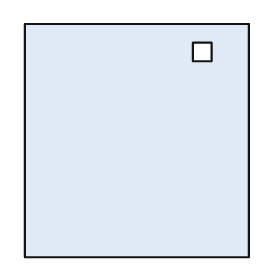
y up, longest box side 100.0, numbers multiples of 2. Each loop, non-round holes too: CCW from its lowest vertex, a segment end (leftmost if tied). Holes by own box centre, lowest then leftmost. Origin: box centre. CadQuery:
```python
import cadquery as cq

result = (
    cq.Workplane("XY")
    .moveTo(-48.0, -50.0)
    .lineTo(48.0, -50.0)
    .lineTo(48.0, 50.0)
    .lineTo(-48.0, 50.0)
    .close()
    .moveTo(24.0, 34.0)
    .lineTo(32.0, 34.0)
    .lineTo(32.0, 42.0)
    .lineTo(24.0, 42.0)
    .close()
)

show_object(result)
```